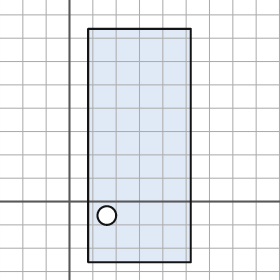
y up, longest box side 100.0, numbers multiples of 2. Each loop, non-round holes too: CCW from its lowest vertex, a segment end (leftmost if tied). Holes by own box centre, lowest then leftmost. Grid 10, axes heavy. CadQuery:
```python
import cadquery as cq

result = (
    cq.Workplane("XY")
    .moveTo(8.0, -26.0)
    .lineTo(52.0, -26.0)
    .lineTo(52.0, 74.0)
    .lineTo(8.0, 74.0)
    .close()
    .moveTo(16.0, -6.0)
    .circle(4.0)
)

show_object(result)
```